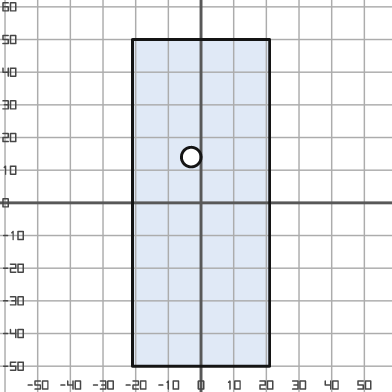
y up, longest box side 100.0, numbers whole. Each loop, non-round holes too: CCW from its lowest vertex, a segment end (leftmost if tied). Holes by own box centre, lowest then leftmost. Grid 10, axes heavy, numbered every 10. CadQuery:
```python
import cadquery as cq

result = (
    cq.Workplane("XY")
    .moveTo(-21.0, -50.0)
    .lineTo(21.0, -50.0)
    .lineTo(21.0, 50.0)
    .lineTo(-21.0, 50.0)
    .close()
    .moveTo(-3.0, 14.0)
    .circle(3.0)
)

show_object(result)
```